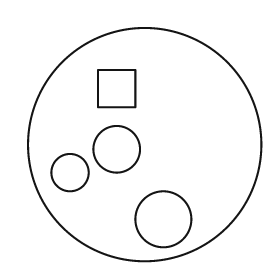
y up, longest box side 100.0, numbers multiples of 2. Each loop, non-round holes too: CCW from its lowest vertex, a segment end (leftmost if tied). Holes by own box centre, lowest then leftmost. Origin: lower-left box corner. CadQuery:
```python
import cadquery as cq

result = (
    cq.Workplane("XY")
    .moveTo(50.0, 50.0)
    .circle(50.0)
    .moveTo(58.0, 18.0)
    .circle(12.0)
    .moveTo(18.0, 38.0)
    .circle(8.0)
    .moveTo(38.0, 48.0)
    .circle(10.0)
    .moveTo(30.0, 66.0)
    .lineTo(46.0, 66.0)
    .lineTo(46.0, 82.0)
    .lineTo(30.0, 82.0)
    .close()
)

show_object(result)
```